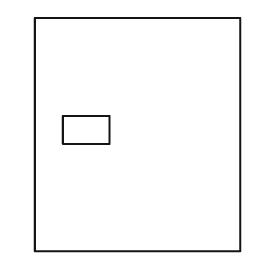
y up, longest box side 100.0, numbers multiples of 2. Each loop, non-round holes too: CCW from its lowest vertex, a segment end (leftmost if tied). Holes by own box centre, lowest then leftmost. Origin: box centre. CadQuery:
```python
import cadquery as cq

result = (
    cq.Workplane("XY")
    .moveTo(-44.0, -50.0)
    .lineTo(44.0, -50.0)
    .lineTo(44.0, 50.0)
    .lineTo(-44.0, 50.0)
    .close()
    .moveTo(-32.0, -4.0)
    .lineTo(-12.0, -4.0)
    .lineTo(-12.0, 8.0)
    .lineTo(-32.0, 8.0)
    .close()
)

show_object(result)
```